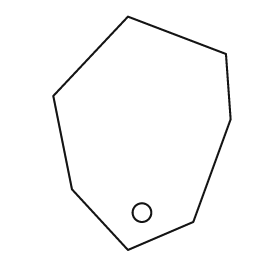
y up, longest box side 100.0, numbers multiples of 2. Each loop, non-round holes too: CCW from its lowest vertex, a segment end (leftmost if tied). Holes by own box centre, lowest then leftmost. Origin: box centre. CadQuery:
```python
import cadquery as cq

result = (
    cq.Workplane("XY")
    .moveTo(-6.0, -50.0)
    .lineTo(22.0, -38.0)
    .lineTo(38.0, 6.0)
    .lineTo(36.0, 34.0)
    .lineTo(-6.0, 50.0)
    .lineTo(-38.0, 16.0)
    .lineTo(-30.0, -24.0)
    .close()
    .moveTo(0.0, -34.0)
    .circle(4.0)
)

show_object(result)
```